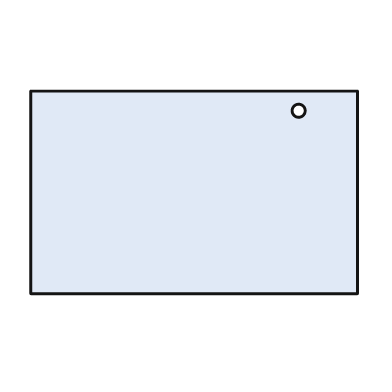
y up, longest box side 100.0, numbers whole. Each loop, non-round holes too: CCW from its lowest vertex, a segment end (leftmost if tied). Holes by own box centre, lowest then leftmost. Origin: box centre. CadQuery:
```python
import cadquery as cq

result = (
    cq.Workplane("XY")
    .moveTo(-50.0, -31.0)
    .lineTo(50.0, -31.0)
    .lineTo(50.0, 31.0)
    .lineTo(-50.0, 31.0)
    .close()
    .moveTo(32.0, 25.0)
    .circle(2.0)
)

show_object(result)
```